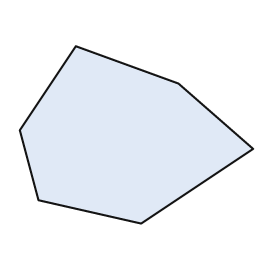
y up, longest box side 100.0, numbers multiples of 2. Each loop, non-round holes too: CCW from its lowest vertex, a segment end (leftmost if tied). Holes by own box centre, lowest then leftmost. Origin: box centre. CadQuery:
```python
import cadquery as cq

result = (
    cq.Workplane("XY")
    .moveTo(2.0, -38.0)
    .lineTo(50.0, -6.0)
    .lineTo(18.0, 22.0)
    .lineTo(-26.0, 38.0)
    .lineTo(-50.0, 2.0)
    .lineTo(-42.0, -28.0)
    .close()
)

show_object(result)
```